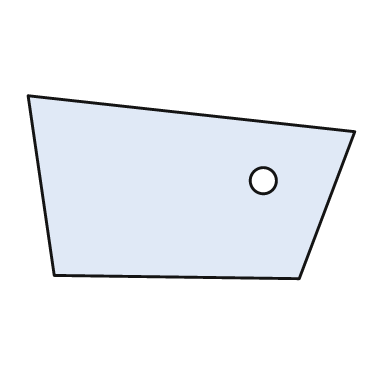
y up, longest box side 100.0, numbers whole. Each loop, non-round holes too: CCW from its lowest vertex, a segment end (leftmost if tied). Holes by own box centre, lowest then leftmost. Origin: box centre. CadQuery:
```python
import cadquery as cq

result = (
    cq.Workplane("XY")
    .moveTo(33.0, -28.0)
    .lineTo(50.0, 17.0)
    .lineTo(-50.0, 28.0)
    .lineTo(-42.0, -27.0)
    .close()
    .moveTo(22.0, 2.0)
    .circle(4.0)
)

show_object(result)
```